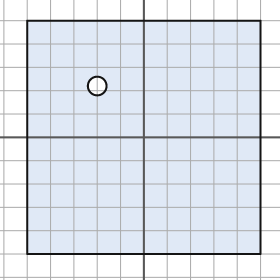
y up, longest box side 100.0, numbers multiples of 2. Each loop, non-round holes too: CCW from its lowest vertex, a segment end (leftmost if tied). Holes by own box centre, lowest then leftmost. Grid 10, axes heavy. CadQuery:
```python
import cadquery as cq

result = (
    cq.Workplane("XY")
    .moveTo(-50.0, -50.0)
    .lineTo(50.0, -50.0)
    .lineTo(50.0, 50.0)
    .lineTo(-50.0, 50.0)
    .close()
    .moveTo(-20.0, 22.0)
    .circle(4.0)
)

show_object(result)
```